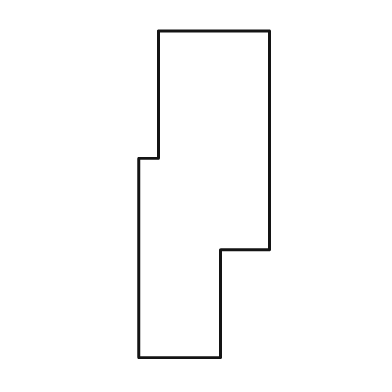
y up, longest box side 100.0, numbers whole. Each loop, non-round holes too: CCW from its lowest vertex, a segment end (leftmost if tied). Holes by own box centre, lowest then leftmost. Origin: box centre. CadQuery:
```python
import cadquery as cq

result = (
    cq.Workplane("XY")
    .moveTo(-20.0, -50.0)
    .lineTo(5.0, -50.0)
    .lineTo(5.0, -17.0)
    .lineTo(20.0, -17.0)
    .lineTo(20.0, 50.0)
    .lineTo(-14.0, 50.0)
    .lineTo(-14.0, 11.0)
    .lineTo(-20.0, 11.0)
    .close()
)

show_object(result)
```